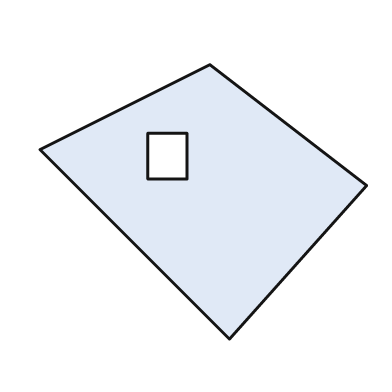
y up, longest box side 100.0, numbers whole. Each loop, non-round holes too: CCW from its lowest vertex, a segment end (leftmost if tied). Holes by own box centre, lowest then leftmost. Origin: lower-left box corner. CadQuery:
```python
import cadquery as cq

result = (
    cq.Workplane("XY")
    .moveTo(58.0, 0.0)
    .lineTo(100.0, 47.0)
    .lineTo(52.0, 84.0)
    .lineTo(0.0, 58.0)
    .close()
    .moveTo(33.0, 49.0)
    .lineTo(45.0, 49.0)
    .lineTo(45.0, 63.0)
    .lineTo(33.0, 63.0)
    .close()
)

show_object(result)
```